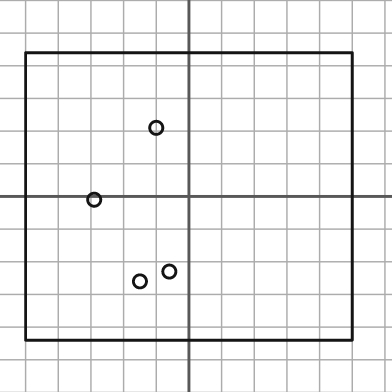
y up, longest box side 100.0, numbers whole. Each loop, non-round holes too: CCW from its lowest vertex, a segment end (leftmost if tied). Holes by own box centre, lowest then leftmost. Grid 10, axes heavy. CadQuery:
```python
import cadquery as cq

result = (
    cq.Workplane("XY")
    .moveTo(-50.0, -44.0)
    .lineTo(50.0, -44.0)
    .lineTo(50.0, 44.0)
    .lineTo(-50.0, 44.0)
    .close()
    .moveTo(-15.0, -26.0)
    .circle(2.0)
    .moveTo(-6.0, -23.0)
    .circle(2.0)
    .moveTo(-29.0, -1.0)
    .circle(2.0)
    .moveTo(-10.0, 21.0)
    .circle(2.0)
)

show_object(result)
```